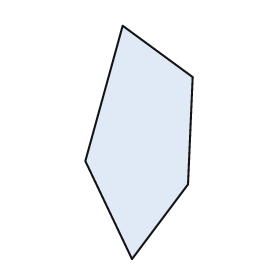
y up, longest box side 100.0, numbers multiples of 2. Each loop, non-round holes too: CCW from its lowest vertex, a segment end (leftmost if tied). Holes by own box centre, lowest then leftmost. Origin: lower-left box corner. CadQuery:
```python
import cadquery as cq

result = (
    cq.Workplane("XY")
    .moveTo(20.0, 0.0)
    .lineTo(44.0, 32.0)
    .lineTo(46.0, 78.0)
    .lineTo(16.0, 100.0)
    .lineTo(0.0, 42.0)
    .close()
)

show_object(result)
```